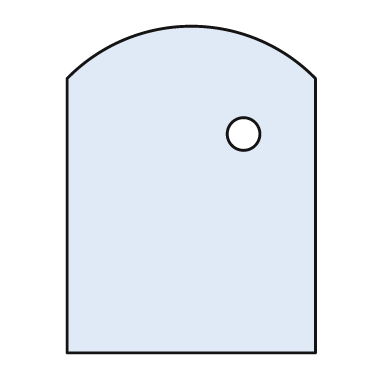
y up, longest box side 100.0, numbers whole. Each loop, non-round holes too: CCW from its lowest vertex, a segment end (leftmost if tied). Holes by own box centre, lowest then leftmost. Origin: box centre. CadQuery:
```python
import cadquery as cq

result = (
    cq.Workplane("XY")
    .moveTo(-38.0, -50.0)
    .lineTo(38.0, -50.0)
    .lineTo(38.0, 34.0)
    .threePointArc((0.0, 50.0), (-38.0, 34.0))
    .close()
    .moveTo(16.0, 17.0)
    .circle(5.0)
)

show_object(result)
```